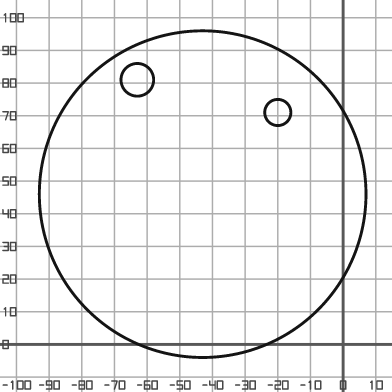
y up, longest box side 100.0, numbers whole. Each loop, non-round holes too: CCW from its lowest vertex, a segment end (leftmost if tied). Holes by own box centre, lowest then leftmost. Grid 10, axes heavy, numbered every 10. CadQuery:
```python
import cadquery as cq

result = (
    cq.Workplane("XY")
    .moveTo(-43.0, 46.0)
    .circle(50.0)
    .moveTo(-20.0, 71.0)
    .circle(4.0)
    .moveTo(-63.0, 81.0)
    .circle(5.0)
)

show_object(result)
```